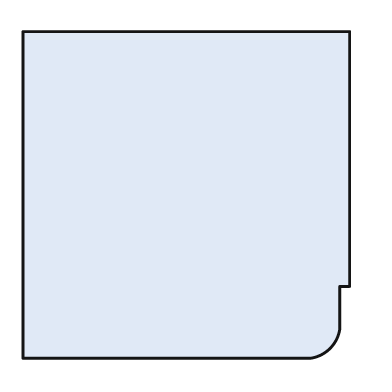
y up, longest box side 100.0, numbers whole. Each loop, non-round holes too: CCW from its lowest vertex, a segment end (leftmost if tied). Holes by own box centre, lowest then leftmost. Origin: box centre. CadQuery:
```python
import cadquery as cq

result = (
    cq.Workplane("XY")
    .moveTo(-50.0, -50.0)
    .lineTo(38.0, -50.0)
    .threePointArc((44.0, -47.0), (47.0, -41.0))
    .lineTo(47.0, -28.0)
    .lineTo(50.0, -28.0)
    .lineTo(50.0, 50.0)
    .lineTo(-50.0, 50.0)
    .close()
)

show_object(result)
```